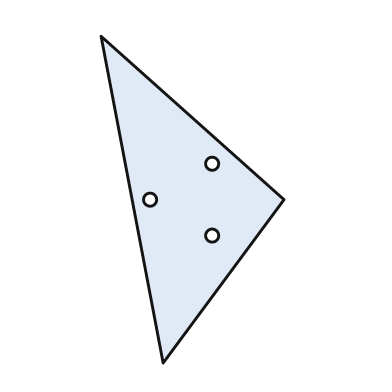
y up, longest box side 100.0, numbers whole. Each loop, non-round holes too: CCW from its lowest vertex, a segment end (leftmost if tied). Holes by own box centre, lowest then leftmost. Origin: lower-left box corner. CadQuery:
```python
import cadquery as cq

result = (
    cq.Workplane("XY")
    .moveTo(19.0, 0.0)
    .lineTo(56.0, 50.0)
    .lineTo(0.0, 100.0)
    .close()
    .moveTo(34.0, 39.0)
    .circle(2.0)
    .moveTo(15.0, 50.0)
    .circle(2.0)
    .moveTo(34.0, 61.0)
    .circle(2.0)
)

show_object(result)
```